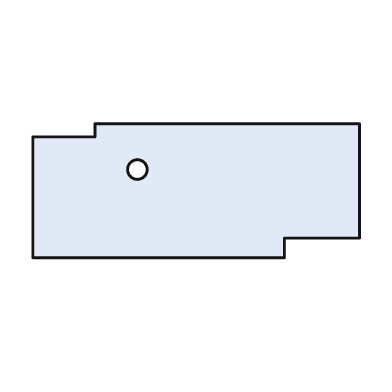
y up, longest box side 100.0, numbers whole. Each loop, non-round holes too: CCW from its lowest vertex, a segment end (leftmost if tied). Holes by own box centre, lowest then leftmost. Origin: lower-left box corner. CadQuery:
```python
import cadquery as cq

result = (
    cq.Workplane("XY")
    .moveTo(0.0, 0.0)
    .lineTo(77.0, 0.0)
    .lineTo(77.0, 6.0)
    .lineTo(100.0, 6.0)
    .lineTo(100.0, 41.0)
    .lineTo(19.0, 41.0)
    .lineTo(19.0, 37.0)
    .lineTo(0.0, 37.0)
    .close()
    .moveTo(32.0, 27.0)
    .circle(3.0)
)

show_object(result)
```